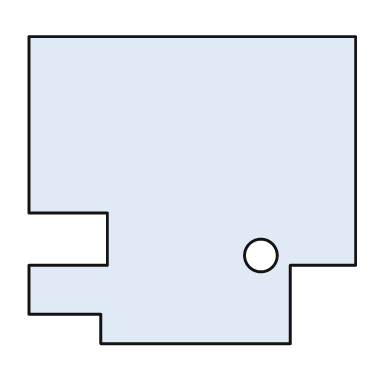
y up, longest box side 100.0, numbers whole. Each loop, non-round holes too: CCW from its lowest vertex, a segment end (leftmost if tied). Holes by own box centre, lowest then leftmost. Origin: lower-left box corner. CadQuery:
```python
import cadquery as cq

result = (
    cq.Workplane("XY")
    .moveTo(22.0, 0.0)
    .lineTo(80.0, 0.0)
    .lineTo(80.0, 24.0)
    .lineTo(100.0, 24.0)
    .lineTo(100.0, 94.0)
    .lineTo(0.0, 94.0)
    .lineTo(0.0, 40.0)
    .lineTo(24.0, 40.0)
    .lineTo(24.0, 24.0)
    .lineTo(0.0, 24.0)
    .lineTo(0.0, 9.0)
    .lineTo(22.0, 9.0)
    .close()
    .moveTo(71.0, 27.0)
    .circle(5.0)
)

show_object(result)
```